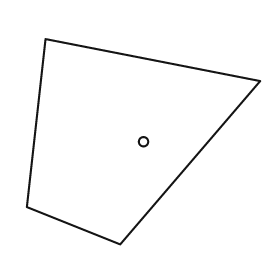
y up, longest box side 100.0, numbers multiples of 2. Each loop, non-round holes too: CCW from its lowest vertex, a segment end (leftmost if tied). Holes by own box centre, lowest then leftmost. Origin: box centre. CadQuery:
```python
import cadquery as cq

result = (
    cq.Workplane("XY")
    .moveTo(-10.0, -44.0)
    .lineTo(50.0, 26.0)
    .lineTo(-42.0, 44.0)
    .lineTo(-50.0, -28.0)
    .close()
    .moveTo(0.0, 0.0)
    .circle(2.0)
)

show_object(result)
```